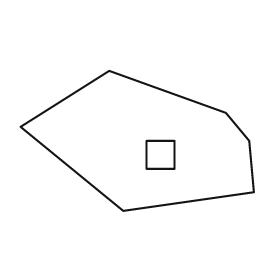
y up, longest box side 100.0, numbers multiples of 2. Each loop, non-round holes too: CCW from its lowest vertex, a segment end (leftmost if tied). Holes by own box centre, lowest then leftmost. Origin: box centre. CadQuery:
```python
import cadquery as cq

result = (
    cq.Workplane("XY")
    .moveTo(-6.0, -30.0)
    .lineTo(50.0, -22.0)
    .lineTo(48.0, 0.0)
    .lineTo(38.0, 12.0)
    .lineTo(-12.0, 30.0)
    .lineTo(-50.0, 6.0)
    .close()
    .moveTo(4.0, -12.0)
    .lineTo(16.0, -12.0)
    .lineTo(16.0, 0.0)
    .lineTo(4.0, 0.0)
    .close()
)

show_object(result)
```